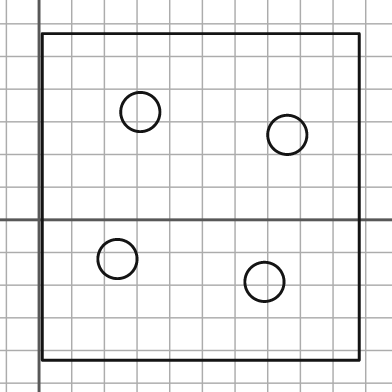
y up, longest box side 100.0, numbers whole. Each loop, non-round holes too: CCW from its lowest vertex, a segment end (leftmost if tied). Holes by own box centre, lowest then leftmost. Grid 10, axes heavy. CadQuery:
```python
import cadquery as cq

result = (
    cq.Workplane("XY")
    .moveTo(1.0, -43.0)
    .lineTo(98.0, -43.0)
    .lineTo(98.0, 57.0)
    .lineTo(1.0, 57.0)
    .close()
    .moveTo(69.0, -19.0)
    .circle(6.0)
    .moveTo(24.0, -12.0)
    .circle(6.0)
    .moveTo(76.0, 26.0)
    .circle(6.0)
    .moveTo(31.0, 33.0)
    .circle(6.0)
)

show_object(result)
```